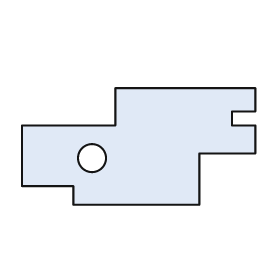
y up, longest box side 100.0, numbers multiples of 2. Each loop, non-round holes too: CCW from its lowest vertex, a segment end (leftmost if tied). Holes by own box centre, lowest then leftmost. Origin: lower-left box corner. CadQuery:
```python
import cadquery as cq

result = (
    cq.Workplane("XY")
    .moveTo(22.0, 0.0)
    .lineTo(76.0, 0.0)
    .lineTo(76.0, 22.0)
    .lineTo(100.0, 22.0)
    .lineTo(100.0, 34.0)
    .lineTo(90.0, 34.0)
    .lineTo(90.0, 40.0)
    .lineTo(100.0, 40.0)
    .lineTo(100.0, 50.0)
    .lineTo(40.0, 50.0)
    .lineTo(40.0, 34.0)
    .lineTo(0.0, 34.0)
    .lineTo(0.0, 8.0)
    .lineTo(22.0, 8.0)
    .close()
    .moveTo(30.0, 20.0)
    .circle(6.0)
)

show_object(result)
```